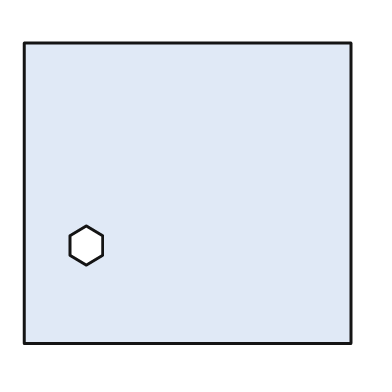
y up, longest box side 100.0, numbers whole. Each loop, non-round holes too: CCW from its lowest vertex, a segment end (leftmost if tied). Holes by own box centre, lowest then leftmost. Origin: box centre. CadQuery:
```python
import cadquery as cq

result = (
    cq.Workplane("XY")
    .moveTo(-50.0, -46.0)
    .lineTo(50.0, -46.0)
    .lineTo(50.0, 46.0)
    .lineTo(-50.0, 46.0)
    .close()
    .moveTo(-31.0, -22.0)
    .lineTo(-26.0, -19.0)
    .lineTo(-26.0, -13.0)
    .lineTo(-31.0, -10.0)
    .lineTo(-36.0, -13.0)
    .lineTo(-36.0, -19.0)
    .close()
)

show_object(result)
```